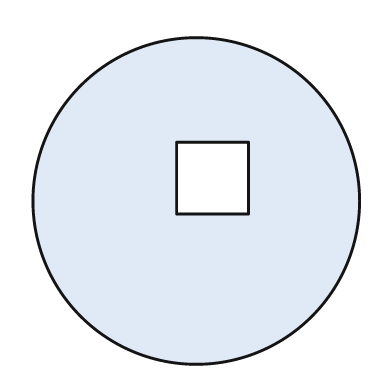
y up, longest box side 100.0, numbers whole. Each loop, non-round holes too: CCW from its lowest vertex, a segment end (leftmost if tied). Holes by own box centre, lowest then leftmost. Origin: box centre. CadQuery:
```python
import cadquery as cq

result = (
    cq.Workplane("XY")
    .moveTo(0.0, 0.0)
    .circle(50.0)
    .moveTo(-6.0, -4.0)
    .lineTo(16.0, -4.0)
    .lineTo(16.0, 18.0)
    .lineTo(-6.0, 18.0)
    .close()
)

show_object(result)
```